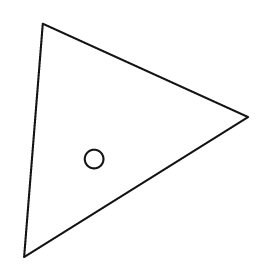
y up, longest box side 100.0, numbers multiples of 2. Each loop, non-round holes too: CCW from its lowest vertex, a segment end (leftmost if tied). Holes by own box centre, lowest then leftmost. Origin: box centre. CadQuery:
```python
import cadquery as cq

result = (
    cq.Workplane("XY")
    .moveTo(-48.0, -50.0)
    .lineTo(48.0, 10.0)
    .lineTo(-40.0, 50.0)
    .close()
    .moveTo(-18.0, -8.0)
    .circle(4.0)
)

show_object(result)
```